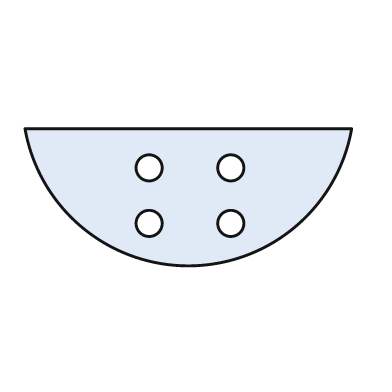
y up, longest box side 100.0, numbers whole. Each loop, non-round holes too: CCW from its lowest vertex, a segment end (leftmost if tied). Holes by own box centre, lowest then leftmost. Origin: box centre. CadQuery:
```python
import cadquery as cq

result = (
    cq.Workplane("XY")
    .moveTo(-50.0, 21.0)
    .threePointArc((0.0, -21.0), (50.0, 21.0))
    .close()
    .moveTo(-12.0, -8.0)
    .circle(4.0)
    .moveTo(13.0, -8.0)
    .circle(4.0)
    .moveTo(-12.0, 9.0)
    .circle(4.0)
    .moveTo(13.0, 9.0)
    .circle(4.0)
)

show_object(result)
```